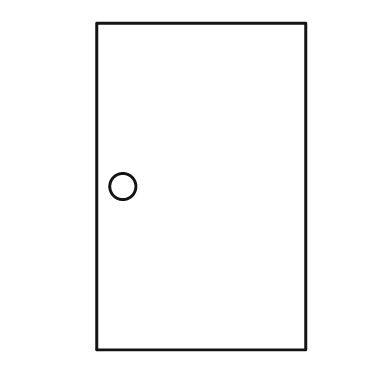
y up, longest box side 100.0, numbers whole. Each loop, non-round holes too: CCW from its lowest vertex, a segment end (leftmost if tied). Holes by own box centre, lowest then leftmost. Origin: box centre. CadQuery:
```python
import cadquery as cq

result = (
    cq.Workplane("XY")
    .moveTo(-32.0, -50.0)
    .lineTo(32.0, -50.0)
    .lineTo(32.0, 50.0)
    .lineTo(-32.0, 50.0)
    .close()
    .moveTo(-24.0, 0.0)
    .circle(4.0)
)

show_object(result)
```